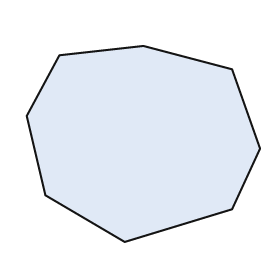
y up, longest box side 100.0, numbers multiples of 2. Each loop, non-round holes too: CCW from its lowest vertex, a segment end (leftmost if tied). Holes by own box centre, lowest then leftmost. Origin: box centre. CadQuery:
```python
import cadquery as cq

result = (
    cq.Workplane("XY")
    .moveTo(-8.0, -42.0)
    .lineTo(38.0, -28.0)
    .lineTo(50.0, -2.0)
    .lineTo(38.0, 32.0)
    .lineTo(0.0, 42.0)
    .lineTo(-36.0, 38.0)
    .lineTo(-50.0, 12.0)
    .lineTo(-42.0, -22.0)
    .close()
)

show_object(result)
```